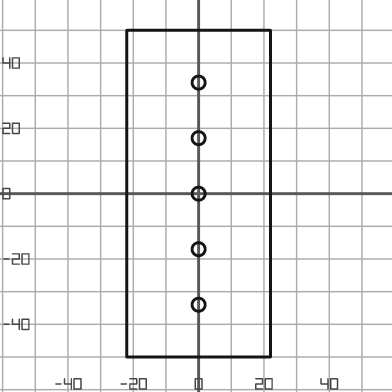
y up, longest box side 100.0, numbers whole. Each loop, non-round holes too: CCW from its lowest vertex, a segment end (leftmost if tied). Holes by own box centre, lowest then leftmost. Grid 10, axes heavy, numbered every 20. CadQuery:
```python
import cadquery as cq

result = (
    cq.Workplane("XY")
    .moveTo(-22.0, -50.0)
    .lineTo(22.0, -50.0)
    .lineTo(22.0, 50.0)
    .lineTo(-22.0, 50.0)
    .close()
    .moveTo(0.0, -34.0)
    .circle(2.0)
    .moveTo(0.0, -17.0)
    .circle(2.0)
    .moveTo(0.0, 0.0)
    .circle(2.0)
    .moveTo(0.0, 17.0)
    .circle(2.0)
    .moveTo(0.0, 34.0)
    .circle(2.0)
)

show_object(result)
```